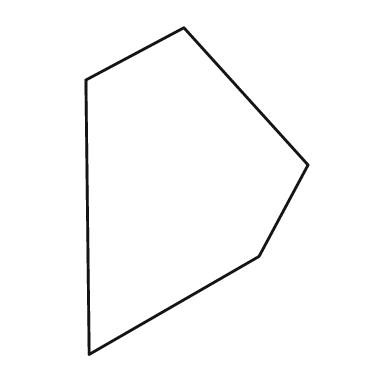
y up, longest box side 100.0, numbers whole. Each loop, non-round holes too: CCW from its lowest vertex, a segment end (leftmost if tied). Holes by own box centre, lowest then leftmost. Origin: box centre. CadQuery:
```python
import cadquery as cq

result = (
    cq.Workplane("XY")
    .moveTo(-33.0, -50.0)
    .lineTo(19.0, -20.0)
    .lineTo(34.0, 8.0)
    .lineTo(-4.0, 50.0)
    .lineTo(-34.0, 34.0)
    .close()
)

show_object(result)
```